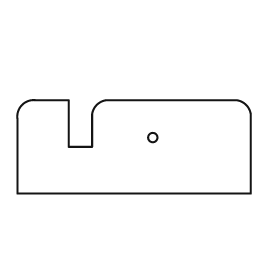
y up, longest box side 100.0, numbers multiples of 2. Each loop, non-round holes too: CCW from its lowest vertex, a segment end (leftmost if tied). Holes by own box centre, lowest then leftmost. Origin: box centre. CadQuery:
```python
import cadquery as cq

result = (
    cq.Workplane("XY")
    .moveTo(-50.0, -20.0)
    .lineTo(50.0, -20.0)
    .lineTo(50.0, 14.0)
    .threePointArc((48.0, 18.0), (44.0, 20.0))
    .lineTo(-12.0, 20.0)
    .threePointArc((-16.0, 18.0), (-18.0, 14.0))
    .lineTo(-18.0, 0.0)
    .lineTo(-28.0, 0.0)
    .lineTo(-28.0, 20.0)
    .lineTo(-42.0, 20.0)
    .threePointArc((-48.0, 18.0), (-50.0, 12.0))
    .close()
    .moveTo(8.0, 4.0)
    .circle(2.0)
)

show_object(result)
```